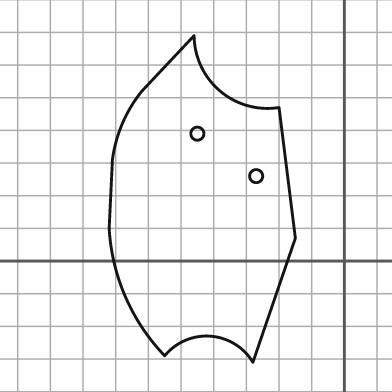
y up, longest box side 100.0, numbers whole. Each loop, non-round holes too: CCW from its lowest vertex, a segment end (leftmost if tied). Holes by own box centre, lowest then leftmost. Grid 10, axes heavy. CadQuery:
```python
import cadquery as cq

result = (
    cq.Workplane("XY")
    .moveTo(-28.0, -31.0)
    .lineTo(-15.0, 7.0)
    .lineTo(-20.0, 47.0)
    .threePointArc((-38.0, 52.0), (-46.0, 69.0))
    .lineTo(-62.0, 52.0)
    .threePointArc((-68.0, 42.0), (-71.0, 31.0))
    .lineTo(-72.0, 10.0)
    .threePointArc((-67.0, -11.0), (-55.0, -29.0))
    .threePointArc((-41.0, -23.0), (-28.0, -31.0))
    .close()
    .moveTo(-27.0, 26.0)
    .circle(2.0)
    .moveTo(-45.0, 39.0)
    .circle(2.0)
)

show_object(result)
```